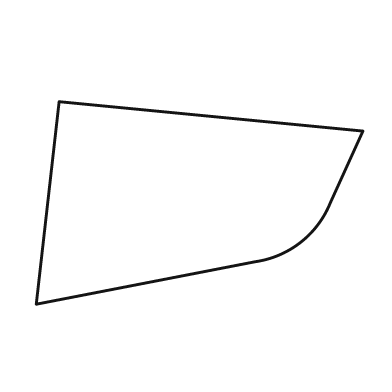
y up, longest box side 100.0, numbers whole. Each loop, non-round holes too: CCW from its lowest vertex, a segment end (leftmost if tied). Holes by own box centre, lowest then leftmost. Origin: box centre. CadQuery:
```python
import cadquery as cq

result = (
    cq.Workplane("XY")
    .moveTo(-50.0, -31.0)
    .lineTo(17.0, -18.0)
    .threePointArc((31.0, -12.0), (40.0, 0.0))
    .lineTo(50.0, 22.0)
    .lineTo(-43.0, 31.0)
    .close()
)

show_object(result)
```